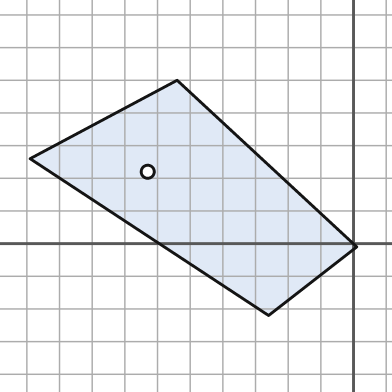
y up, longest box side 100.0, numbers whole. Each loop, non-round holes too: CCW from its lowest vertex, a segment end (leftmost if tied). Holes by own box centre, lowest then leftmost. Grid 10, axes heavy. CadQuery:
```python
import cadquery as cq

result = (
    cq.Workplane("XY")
    .moveTo(-26.0, -22.0)
    .lineTo(1.0, -1.0)
    .lineTo(-54.0, 50.0)
    .lineTo(-99.0, 26.0)
    .close()
    .moveTo(-63.0, 22.0)
    .circle(2.0)
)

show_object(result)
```